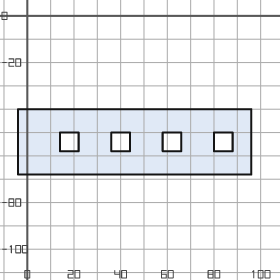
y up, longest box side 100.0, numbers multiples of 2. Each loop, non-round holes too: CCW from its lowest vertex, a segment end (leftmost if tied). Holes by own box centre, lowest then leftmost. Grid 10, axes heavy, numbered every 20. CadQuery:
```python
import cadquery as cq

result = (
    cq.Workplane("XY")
    .moveTo(-4.0, -68.0)
    .lineTo(96.0, -68.0)
    .lineTo(96.0, -40.0)
    .lineTo(-4.0, -40.0)
    .close()
    .moveTo(14.0, -58.0)
    .lineTo(22.0, -58.0)
    .lineTo(22.0, -50.0)
    .lineTo(14.0, -50.0)
    .close()
    .moveTo(36.0, -58.0)
    .lineTo(44.0, -58.0)
    .lineTo(44.0, -50.0)
    .lineTo(36.0, -50.0)
    .close()
    .moveTo(58.0, -58.0)
    .lineTo(66.0, -58.0)
    .lineTo(66.0, -50.0)
    .lineTo(58.0, -50.0)
    .close()
    .moveTo(80.0, -58.0)
    .lineTo(88.0, -58.0)
    .lineTo(88.0, -50.0)
    .lineTo(80.0, -50.0)
    .close()
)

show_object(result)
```